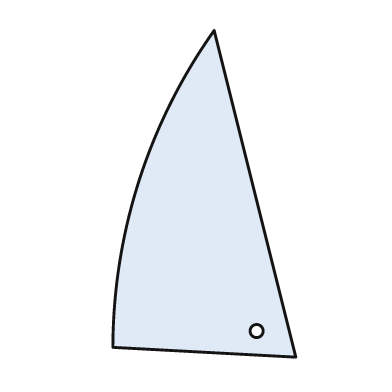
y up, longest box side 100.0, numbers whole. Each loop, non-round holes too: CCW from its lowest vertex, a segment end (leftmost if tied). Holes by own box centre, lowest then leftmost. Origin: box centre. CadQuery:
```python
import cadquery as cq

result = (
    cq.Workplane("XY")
    .moveTo(28.0, -50.0)
    .lineTo(3.0, 50.0)
    .threePointArc((-20.0, 4.0), (-28.0, -47.0))
    .close()
    .moveTo(16.0, -42.0)
    .circle(2.0)
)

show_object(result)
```